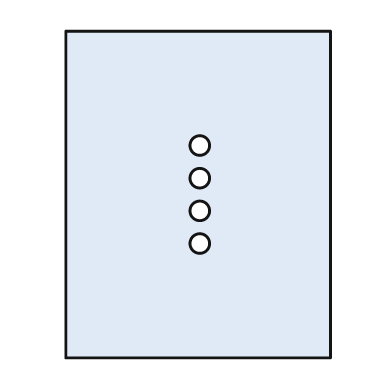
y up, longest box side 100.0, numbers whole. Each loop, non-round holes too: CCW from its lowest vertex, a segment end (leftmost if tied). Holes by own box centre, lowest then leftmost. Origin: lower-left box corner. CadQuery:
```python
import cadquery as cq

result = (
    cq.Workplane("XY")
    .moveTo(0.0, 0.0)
    .lineTo(81.0, 0.0)
    .lineTo(81.0, 100.0)
    .lineTo(0.0, 100.0)
    .close()
    .moveTo(41.0, 35.0)
    .circle(3.0)
    .moveTo(41.0, 45.0)
    .circle(3.0)
    .moveTo(41.0, 55.0)
    .circle(3.0)
    .moveTo(41.0, 65.0)
    .circle(3.0)
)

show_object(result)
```